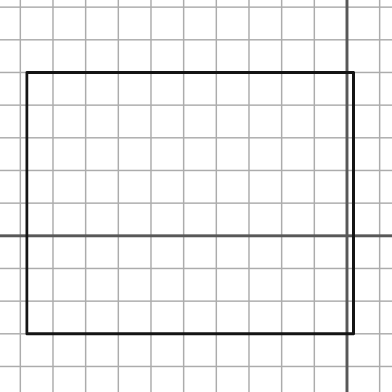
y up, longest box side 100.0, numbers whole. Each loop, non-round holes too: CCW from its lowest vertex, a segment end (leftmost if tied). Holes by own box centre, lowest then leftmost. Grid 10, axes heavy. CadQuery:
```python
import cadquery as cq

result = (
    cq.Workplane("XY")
    .moveTo(-98.0, -30.0)
    .lineTo(2.0, -30.0)
    .lineTo(2.0, 50.0)
    .lineTo(-98.0, 50.0)
    .close()
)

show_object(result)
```